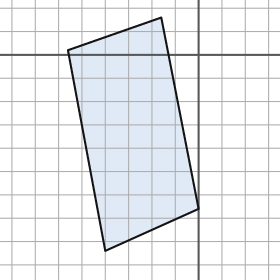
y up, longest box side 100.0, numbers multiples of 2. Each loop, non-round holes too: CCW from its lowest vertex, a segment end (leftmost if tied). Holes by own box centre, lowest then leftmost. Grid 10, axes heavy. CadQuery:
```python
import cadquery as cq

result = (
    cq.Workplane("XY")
    .moveTo(-40.0, -84.0)
    .lineTo(0.0, -66.0)
    .lineTo(-16.0, 16.0)
    .lineTo(-56.0, 2.0)
    .close()
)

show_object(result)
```